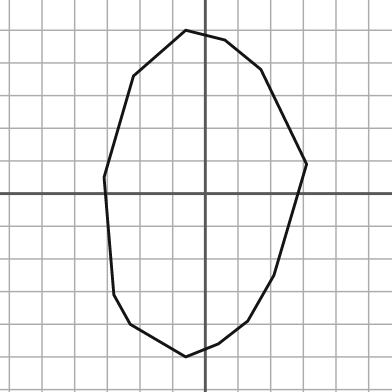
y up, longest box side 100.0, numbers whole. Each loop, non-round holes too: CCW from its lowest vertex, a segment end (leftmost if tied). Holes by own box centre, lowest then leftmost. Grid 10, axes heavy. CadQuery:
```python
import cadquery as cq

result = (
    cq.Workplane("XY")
    .moveTo(-6.0, -50.0)
    .lineTo(4.0, -46.0)
    .lineTo(13.0, -39.0)
    .lineTo(21.0, -25.0)
    .lineTo(31.0, 9.0)
    .lineTo(17.0, 38.0)
    .lineTo(6.0, 47.0)
    .lineTo(-6.0, 50.0)
    .lineTo(-22.0, 36.0)
    .lineTo(-31.0, 5.0)
    .lineTo(-28.0, -31.0)
    .lineTo(-23.0, -40.0)
    .close()
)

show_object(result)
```